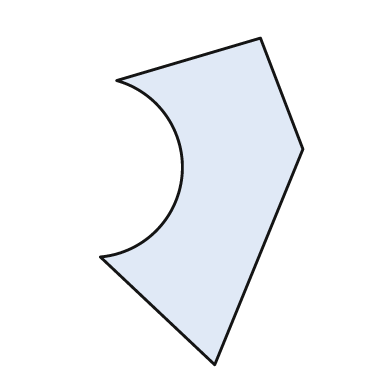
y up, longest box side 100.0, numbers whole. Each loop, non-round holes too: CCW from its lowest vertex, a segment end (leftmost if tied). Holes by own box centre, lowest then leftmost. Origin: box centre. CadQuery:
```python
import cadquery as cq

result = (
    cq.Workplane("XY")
    .moveTo(4.0, -50.0)
    .lineTo(31.0, 16.0)
    .lineTo(18.0, 50.0)
    .lineTo(-26.0, 37.0)
    .threePointArc((-6.0, 8.0), (-31.0, -17.0))
    .close()
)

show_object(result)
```